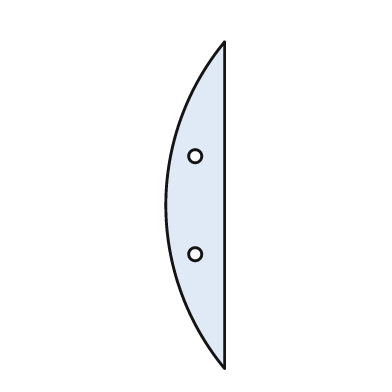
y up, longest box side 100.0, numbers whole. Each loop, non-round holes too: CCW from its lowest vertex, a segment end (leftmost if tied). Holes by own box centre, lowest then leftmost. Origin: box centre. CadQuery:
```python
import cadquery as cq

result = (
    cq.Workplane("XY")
    .moveTo(9.0, -50.0)
    .lineTo(9.0, 50.0)
    .threePointArc((-9.0, 0.0), (9.0, -50.0))
    .close()
    .moveTo(0.0, -15.0)
    .circle(2.0)
    .moveTo(0.0, 15.0)
    .circle(2.0)
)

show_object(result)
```